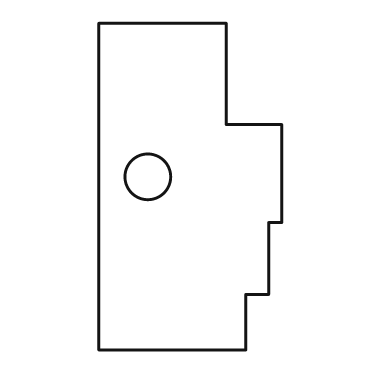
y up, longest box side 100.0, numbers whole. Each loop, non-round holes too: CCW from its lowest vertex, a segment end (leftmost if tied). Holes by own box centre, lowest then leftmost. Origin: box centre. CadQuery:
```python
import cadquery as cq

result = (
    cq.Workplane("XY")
    .moveTo(-28.0, -50.0)
    .lineTo(17.0, -50.0)
    .lineTo(17.0, -33.0)
    .lineTo(24.0, -33.0)
    .lineTo(24.0, -11.0)
    .lineTo(28.0, -11.0)
    .lineTo(28.0, 19.0)
    .lineTo(11.0, 19.0)
    .lineTo(11.0, 50.0)
    .lineTo(-28.0, 50.0)
    .close()
    .moveTo(-13.0, 3.0)
    .circle(7.0)
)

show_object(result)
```